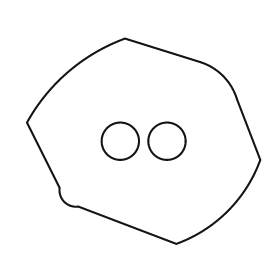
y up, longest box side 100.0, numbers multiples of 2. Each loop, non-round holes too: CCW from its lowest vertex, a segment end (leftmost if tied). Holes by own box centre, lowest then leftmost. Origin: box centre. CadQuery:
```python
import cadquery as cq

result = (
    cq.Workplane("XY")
    .moveTo(14.0, -44.0)
    .threePointArc((36.0, -30.0), (50.0, -8.0))
    .lineTo(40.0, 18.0)
    .threePointArc((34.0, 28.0), (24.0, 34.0))
    .lineTo(-8.0, 44.0)
    .threePointArc((-32.0, 30.0), (-50.0, 8.0))
    .lineTo(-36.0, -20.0)
    .threePointArc((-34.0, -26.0), (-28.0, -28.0))
    .close()
    .moveTo(-10.0, 0.0)
    .circle(8.0)
    .moveTo(10.0, 0.0)
    .circle(8.0)
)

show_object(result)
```